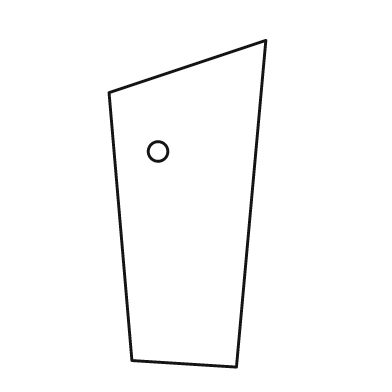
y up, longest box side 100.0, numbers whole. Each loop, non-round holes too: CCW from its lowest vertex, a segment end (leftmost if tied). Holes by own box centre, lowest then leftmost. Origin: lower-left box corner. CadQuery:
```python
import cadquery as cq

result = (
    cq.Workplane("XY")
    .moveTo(39.0, 0.0)
    .lineTo(48.0, 100.0)
    .lineTo(0.0, 84.0)
    .lineTo(7.0, 2.0)
    .close()
    .moveTo(15.0, 66.0)
    .circle(3.0)
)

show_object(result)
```